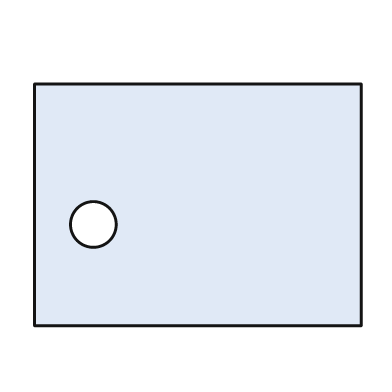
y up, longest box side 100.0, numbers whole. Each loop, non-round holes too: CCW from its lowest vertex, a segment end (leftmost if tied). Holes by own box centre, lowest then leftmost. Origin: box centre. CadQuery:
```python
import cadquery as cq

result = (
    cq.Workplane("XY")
    .moveTo(-50.0, -37.0)
    .lineTo(50.0, -37.0)
    .lineTo(50.0, 37.0)
    .lineTo(-50.0, 37.0)
    .close()
    .moveTo(-32.0, -6.0)
    .circle(7.0)
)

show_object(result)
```